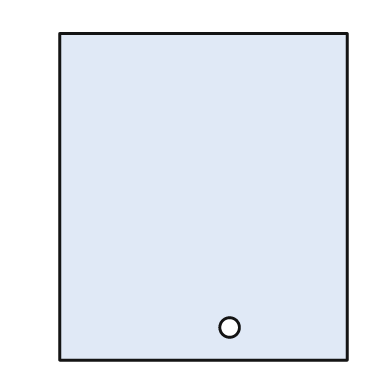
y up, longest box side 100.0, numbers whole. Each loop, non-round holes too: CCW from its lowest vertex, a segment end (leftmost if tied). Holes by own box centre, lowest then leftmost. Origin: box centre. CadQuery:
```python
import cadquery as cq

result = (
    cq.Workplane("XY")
    .moveTo(-44.0, -50.0)
    .lineTo(44.0, -50.0)
    .lineTo(44.0, 50.0)
    .lineTo(-44.0, 50.0)
    .close()
    .moveTo(8.0, -40.0)
    .circle(3.0)
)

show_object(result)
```